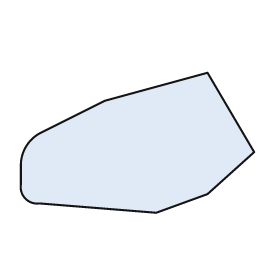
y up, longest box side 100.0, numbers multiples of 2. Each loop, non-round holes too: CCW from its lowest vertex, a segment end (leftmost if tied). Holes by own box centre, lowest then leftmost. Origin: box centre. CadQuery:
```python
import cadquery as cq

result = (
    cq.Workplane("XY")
    .moveTo(8.0, -30.0)
    .lineTo(30.0, -22.0)
    .lineTo(50.0, -4.0)
    .lineTo(30.0, 30.0)
    .lineTo(-14.0, 18.0)
    .lineTo(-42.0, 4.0)
    .threePointArc((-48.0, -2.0), (-50.0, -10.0))
    .lineTo(-50.0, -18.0)
    .threePointArc((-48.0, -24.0), (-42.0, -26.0))
    .close()
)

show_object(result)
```